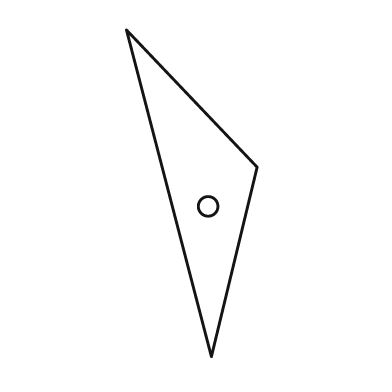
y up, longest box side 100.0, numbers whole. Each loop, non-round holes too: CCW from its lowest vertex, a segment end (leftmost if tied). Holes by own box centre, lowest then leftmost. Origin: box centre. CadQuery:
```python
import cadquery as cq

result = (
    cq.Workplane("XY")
    .moveTo(6.0, -50.0)
    .lineTo(20.0, 8.0)
    .lineTo(-20.0, 50.0)
    .close()
    .moveTo(5.0, -4.0)
    .circle(3.0)
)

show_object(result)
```